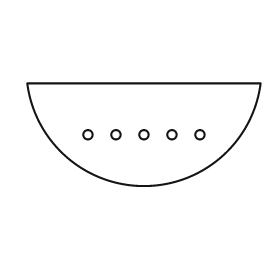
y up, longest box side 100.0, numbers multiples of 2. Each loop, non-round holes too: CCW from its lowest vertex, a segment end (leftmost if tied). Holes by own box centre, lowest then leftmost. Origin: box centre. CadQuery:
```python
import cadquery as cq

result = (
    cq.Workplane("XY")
    .moveTo(-50.0, 22.0)
    .threePointArc((0.0, -22.0), (50.0, 22.0))
    .close()
    .moveTo(-24.0, 0.0)
    .circle(2.0)
    .moveTo(-12.0, 0.0)
    .circle(2.0)
    .moveTo(0.0, 0.0)
    .circle(2.0)
    .moveTo(12.0, 0.0)
    .circle(2.0)
    .moveTo(24.0, 0.0)
    .circle(2.0)
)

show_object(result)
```